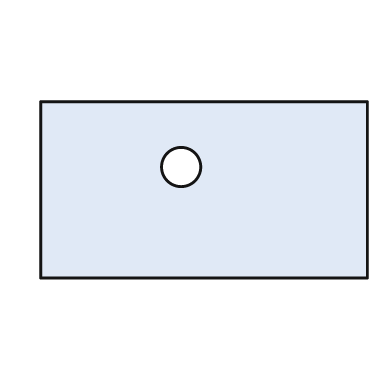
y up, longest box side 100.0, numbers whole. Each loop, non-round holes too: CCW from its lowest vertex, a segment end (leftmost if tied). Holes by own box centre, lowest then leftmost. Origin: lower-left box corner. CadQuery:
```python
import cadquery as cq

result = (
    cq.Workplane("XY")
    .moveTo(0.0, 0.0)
    .lineTo(100.0, 0.0)
    .lineTo(100.0, 54.0)
    .lineTo(0.0, 54.0)
    .close()
    .moveTo(43.0, 34.0)
    .circle(6.0)
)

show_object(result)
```